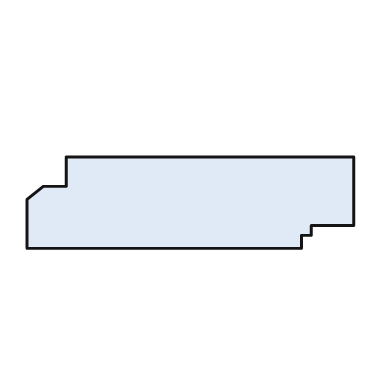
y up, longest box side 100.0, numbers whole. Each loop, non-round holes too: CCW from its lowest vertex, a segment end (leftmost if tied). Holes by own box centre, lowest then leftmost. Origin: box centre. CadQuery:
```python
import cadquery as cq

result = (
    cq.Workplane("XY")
    .moveTo(-50.0, -14.0)
    .lineTo(34.0, -14.0)
    .lineTo(34.0, -10.0)
    .lineTo(37.0, -10.0)
    .lineTo(37.0, -7.0)
    .lineTo(50.0, -7.0)
    .lineTo(50.0, 14.0)
    .lineTo(-38.0, 14.0)
    .lineTo(-38.0, 5.0)
    .lineTo(-45.0, 5.0)
    .lineTo(-50.0, 1.0)
    .close()
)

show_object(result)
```